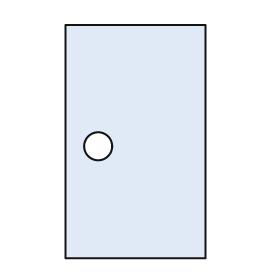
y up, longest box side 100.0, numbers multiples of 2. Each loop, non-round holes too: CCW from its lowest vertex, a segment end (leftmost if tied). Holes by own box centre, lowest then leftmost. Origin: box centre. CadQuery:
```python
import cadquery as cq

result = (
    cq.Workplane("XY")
    .moveTo(-30.0, -50.0)
    .lineTo(30.0, -50.0)
    .lineTo(30.0, 50.0)
    .lineTo(-30.0, 50.0)
    .close()
    .moveTo(-16.0, -2.0)
    .circle(6.0)
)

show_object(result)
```